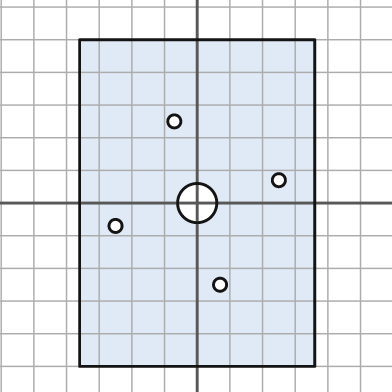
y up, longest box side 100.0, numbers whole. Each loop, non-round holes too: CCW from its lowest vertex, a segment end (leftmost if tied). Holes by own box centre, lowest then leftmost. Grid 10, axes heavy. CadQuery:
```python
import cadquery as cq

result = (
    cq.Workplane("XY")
    .moveTo(-36.0, -50.0)
    .lineTo(36.0, -50.0)
    .lineTo(36.0, 50.0)
    .lineTo(-36.0, 50.0)
    .close()
    .moveTo(7.0, -25.0)
    .circle(2.0)
    .moveTo(-25.0, -7.0)
    .circle(2.0)
    .moveTo(0.0, 0.0)
    .circle(6.0)
    .moveTo(25.0, 7.0)
    .circle(2.0)
    .moveTo(-7.0, 25.0)
    .circle(2.0)
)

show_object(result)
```